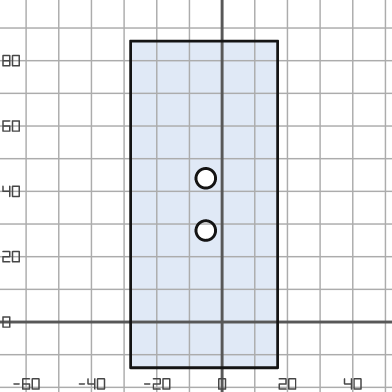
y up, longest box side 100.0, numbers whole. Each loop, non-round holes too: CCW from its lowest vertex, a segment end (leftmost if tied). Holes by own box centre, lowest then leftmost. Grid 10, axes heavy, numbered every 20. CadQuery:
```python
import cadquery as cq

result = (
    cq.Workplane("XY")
    .moveTo(-28.0, -14.0)
    .lineTo(17.0, -14.0)
    .lineTo(17.0, 86.0)
    .lineTo(-28.0, 86.0)
    .close()
    .moveTo(-5.0, 28.0)
    .circle(3.0)
    .moveTo(-5.0, 44.0)
    .circle(3.0)
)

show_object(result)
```